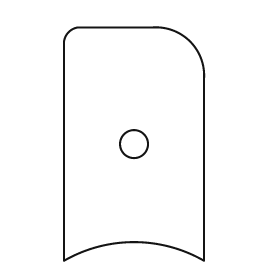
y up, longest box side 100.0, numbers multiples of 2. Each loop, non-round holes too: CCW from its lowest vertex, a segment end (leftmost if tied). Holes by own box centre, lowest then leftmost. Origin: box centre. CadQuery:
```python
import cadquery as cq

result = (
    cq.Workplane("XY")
    .moveTo(-30.0, -50.0)
    .threePointArc((0.0, -42.0), (30.0, -50.0))
    .lineTo(30.0, 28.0)
    .threePointArc((24.0, 44.0), (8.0, 50.0))
    .lineTo(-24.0, 50.0)
    .threePointArc((-28.0, 48.0), (-30.0, 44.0))
    .close()
    .moveTo(0.0, 0.0)
    .circle(6.0)
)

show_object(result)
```